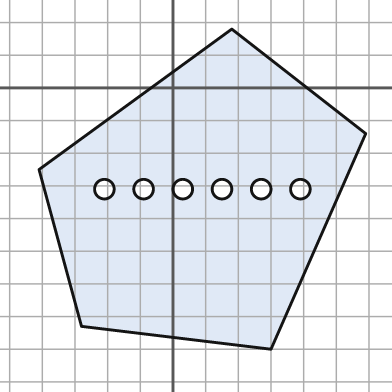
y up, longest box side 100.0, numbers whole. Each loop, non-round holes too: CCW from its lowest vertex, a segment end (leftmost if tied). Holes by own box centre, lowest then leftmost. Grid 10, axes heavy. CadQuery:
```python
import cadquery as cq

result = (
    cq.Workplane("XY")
    .moveTo(30.0, -80.0)
    .lineTo(59.0, -14.0)
    .lineTo(18.0, 18.0)
    .lineTo(-41.0, -25.0)
    .lineTo(-28.0, -73.0)
    .close()
    .moveTo(-21.0, -31.0)
    .circle(3.0)
    .moveTo(-9.0, -31.0)
    .circle(3.0)
    .moveTo(3.0, -31.0)
    .circle(3.0)
    .moveTo(15.0, -31.0)
    .circle(3.0)
    .moveTo(27.0, -31.0)
    .circle(3.0)
    .moveTo(39.0, -31.0)
    .circle(3.0)
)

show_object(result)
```